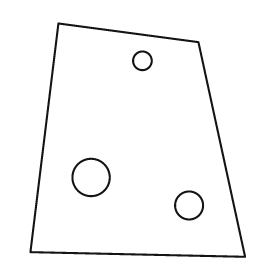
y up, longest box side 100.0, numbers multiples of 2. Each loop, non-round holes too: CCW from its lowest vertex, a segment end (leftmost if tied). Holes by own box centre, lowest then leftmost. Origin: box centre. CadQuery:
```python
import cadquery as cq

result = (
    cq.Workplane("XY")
    .moveTo(46.0, -50.0)
    .lineTo(26.0, 42.0)
    .lineTo(-34.0, 50.0)
    .lineTo(-46.0, -48.0)
    .close()
    .moveTo(22.0, -28.0)
    .circle(6.0)
    .moveTo(-20.0, -16.0)
    .circle(8.0)
    .moveTo(2.0, 34.0)
    .circle(4.0)
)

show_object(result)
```